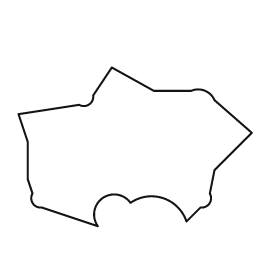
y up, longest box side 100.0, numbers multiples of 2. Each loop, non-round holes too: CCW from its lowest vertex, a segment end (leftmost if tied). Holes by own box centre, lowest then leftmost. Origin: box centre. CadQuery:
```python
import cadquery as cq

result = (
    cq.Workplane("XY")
    .moveTo(-16.0, -34.0)
    .threePointArc((-14.0, -22.0), (-2.0, -24.0))
    .threePointArc((12.0, -22.0), (22.0, -32.0))
    .lineTo(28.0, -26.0)
    .threePointArc((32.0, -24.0), (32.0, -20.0))
    .lineTo(34.0, -10.0)
    .lineTo(50.0, 6.0)
    .lineTo(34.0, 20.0)
    .threePointArc((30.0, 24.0), (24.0, 24.0))
    .lineTo(8.0, 24.0)
    .lineTo(-10.0, 34.0)
    .lineTo(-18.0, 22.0)
    .threePointArc((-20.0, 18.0), (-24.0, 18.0))
    .lineTo(-50.0, 14.0)
    .lineTo(-46.0, 2.0)
    .lineTo(-46.0, -14.0)
    .lineTo(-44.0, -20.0)
    .threePointArc((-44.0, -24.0), (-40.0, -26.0))
    .close()
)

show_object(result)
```